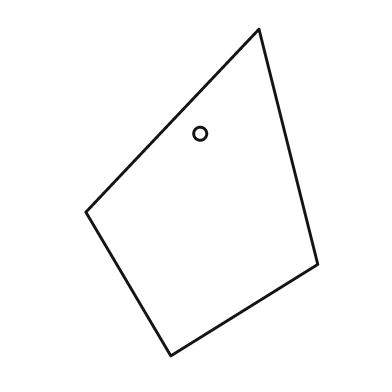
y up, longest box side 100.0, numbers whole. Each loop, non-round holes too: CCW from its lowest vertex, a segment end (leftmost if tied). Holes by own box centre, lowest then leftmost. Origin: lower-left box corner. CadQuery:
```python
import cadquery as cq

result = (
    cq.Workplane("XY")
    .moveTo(26.0, 0.0)
    .lineTo(71.0, 28.0)
    .lineTo(53.0, 100.0)
    .lineTo(0.0, 44.0)
    .close()
    .moveTo(35.0, 68.0)
    .circle(2.0)
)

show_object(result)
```